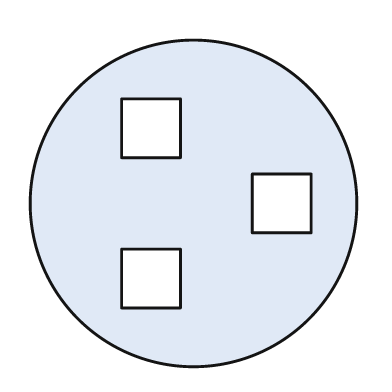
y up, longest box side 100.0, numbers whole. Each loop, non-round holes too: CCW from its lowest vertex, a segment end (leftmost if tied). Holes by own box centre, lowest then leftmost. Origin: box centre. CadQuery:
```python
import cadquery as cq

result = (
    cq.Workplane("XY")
    .moveTo(0.0, 0.0)
    .circle(50.0)
    .moveTo(-22.0, -32.0)
    .lineTo(-4.0, -32.0)
    .lineTo(-4.0, -14.0)
    .lineTo(-22.0, -14.0)
    .close()
    .moveTo(18.0, -9.0)
    .lineTo(36.0, -9.0)
    .lineTo(36.0, 9.0)
    .lineTo(18.0, 9.0)
    .close()
    .moveTo(-22.0, 14.0)
    .lineTo(-4.0, 14.0)
    .lineTo(-4.0, 32.0)
    .lineTo(-22.0, 32.0)
    .close()
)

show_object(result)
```